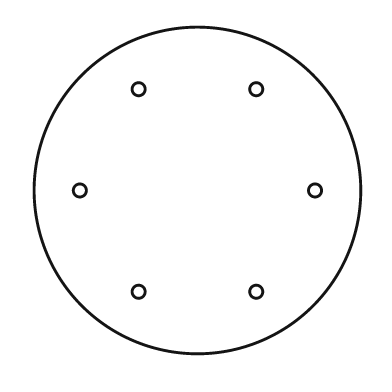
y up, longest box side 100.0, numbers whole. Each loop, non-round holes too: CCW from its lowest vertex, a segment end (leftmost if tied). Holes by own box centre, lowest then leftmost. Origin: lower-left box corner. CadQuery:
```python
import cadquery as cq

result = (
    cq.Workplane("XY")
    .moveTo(50.0, 50.0)
    .circle(50.0)
    .moveTo(32.0, 19.0)
    .circle(2.0)
    .moveTo(68.0, 19.0)
    .circle(2.0)
    .moveTo(14.0, 50.0)
    .circle(2.0)
    .moveTo(86.0, 50.0)
    .circle(2.0)
    .moveTo(32.0, 81.0)
    .circle(2.0)
    .moveTo(68.0, 81.0)
    .circle(2.0)
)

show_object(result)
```